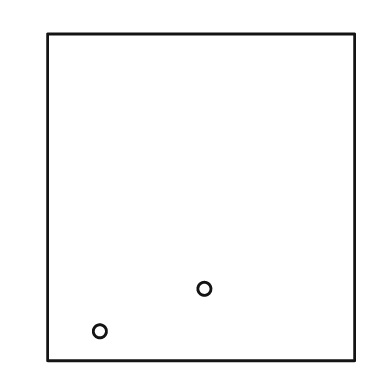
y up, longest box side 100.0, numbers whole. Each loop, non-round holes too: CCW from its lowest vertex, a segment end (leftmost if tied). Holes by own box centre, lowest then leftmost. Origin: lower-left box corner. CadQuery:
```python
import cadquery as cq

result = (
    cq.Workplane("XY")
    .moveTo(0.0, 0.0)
    .lineTo(94.0, 0.0)
    .lineTo(94.0, 100.0)
    .lineTo(0.0, 100.0)
    .close()
    .moveTo(16.0, 9.0)
    .circle(2.0)
    .moveTo(48.0, 22.0)
    .circle(2.0)
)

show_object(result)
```